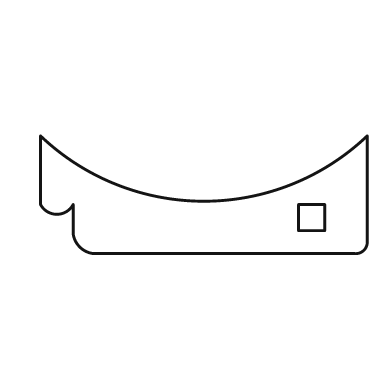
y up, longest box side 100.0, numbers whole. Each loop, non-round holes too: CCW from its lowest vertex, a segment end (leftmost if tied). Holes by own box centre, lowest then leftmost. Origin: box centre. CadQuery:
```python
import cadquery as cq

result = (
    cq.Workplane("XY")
    .moveTo(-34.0, -18.0)
    .lineTo(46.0, -18.0)
    .threePointArc((49.0, -17.0), (50.0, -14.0))
    .lineTo(50.0, 18.0)
    .threePointArc((0.0, -2.0), (-50.0, 18.0))
    .lineTo(-50.0, -3.0)
    .threePointArc((-45.0, -6.0), (-40.0, -3.0))
    .lineTo(-40.0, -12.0)
    .threePointArc((-38.0, -16.0), (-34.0, -18.0))
    .close()
    .moveTo(29.0, -11.0)
    .lineTo(37.0, -11.0)
    .lineTo(37.0, -3.0)
    .lineTo(29.0, -3.0)
    .close()
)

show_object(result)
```